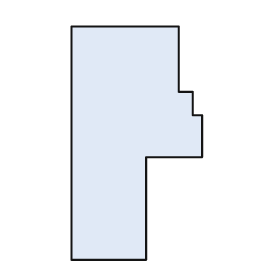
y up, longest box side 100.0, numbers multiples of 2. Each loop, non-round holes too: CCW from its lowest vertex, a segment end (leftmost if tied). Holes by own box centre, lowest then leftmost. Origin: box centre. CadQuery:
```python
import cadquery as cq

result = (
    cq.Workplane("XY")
    .moveTo(-28.0, -50.0)
    .lineTo(4.0, -50.0)
    .lineTo(4.0, -6.0)
    .lineTo(28.0, -6.0)
    .lineTo(28.0, 12.0)
    .lineTo(24.0, 12.0)
    .lineTo(24.0, 22.0)
    .lineTo(18.0, 22.0)
    .lineTo(18.0, 50.0)
    .lineTo(-28.0, 50.0)
    .close()
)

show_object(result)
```